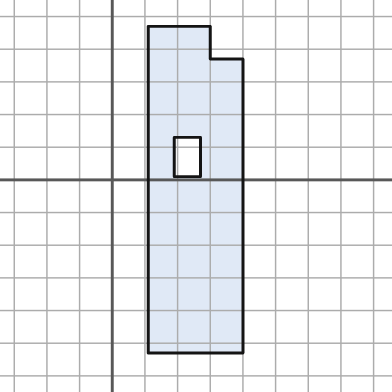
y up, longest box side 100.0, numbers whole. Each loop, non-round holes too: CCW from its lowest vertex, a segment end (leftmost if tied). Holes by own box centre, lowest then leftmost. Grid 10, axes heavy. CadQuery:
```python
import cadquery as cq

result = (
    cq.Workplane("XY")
    .moveTo(11.0, -53.0)
    .lineTo(40.0, -53.0)
    .lineTo(40.0, 37.0)
    .lineTo(30.0, 37.0)
    .lineTo(30.0, 47.0)
    .lineTo(11.0, 47.0)
    .close()
    .moveTo(19.0, 1.0)
    .lineTo(27.0, 1.0)
    .lineTo(27.0, 13.0)
    .lineTo(19.0, 13.0)
    .close()
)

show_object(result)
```